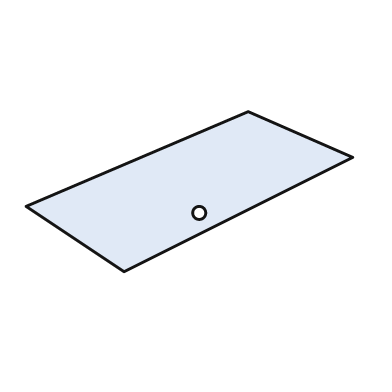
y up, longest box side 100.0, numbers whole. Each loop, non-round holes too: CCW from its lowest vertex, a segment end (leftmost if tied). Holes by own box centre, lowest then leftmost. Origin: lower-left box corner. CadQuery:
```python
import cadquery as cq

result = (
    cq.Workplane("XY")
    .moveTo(30.0, 0.0)
    .lineTo(100.0, 35.0)
    .lineTo(68.0, 49.0)
    .lineTo(0.0, 20.0)
    .close()
    .moveTo(53.0, 18.0)
    .circle(2.0)
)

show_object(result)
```